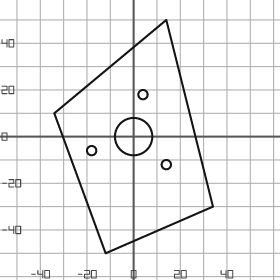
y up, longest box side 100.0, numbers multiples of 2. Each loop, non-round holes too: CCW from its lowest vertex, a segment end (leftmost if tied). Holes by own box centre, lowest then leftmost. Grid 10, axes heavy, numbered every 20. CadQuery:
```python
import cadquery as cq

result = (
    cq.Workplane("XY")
    .moveTo(-12.0, -50.0)
    .lineTo(34.0, -30.0)
    .lineTo(14.0, 50.0)
    .lineTo(-34.0, 10.0)
    .close()
    .moveTo(14.0, -12.0)
    .circle(2.0)
    .moveTo(-18.0, -6.0)
    .circle(2.0)
    .moveTo(0.0, 0.0)
    .circle(8.0)
    .moveTo(4.0, 18.0)
    .circle(2.0)
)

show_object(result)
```